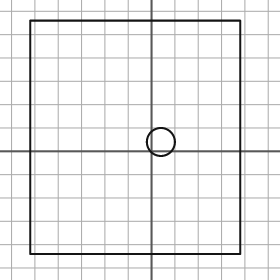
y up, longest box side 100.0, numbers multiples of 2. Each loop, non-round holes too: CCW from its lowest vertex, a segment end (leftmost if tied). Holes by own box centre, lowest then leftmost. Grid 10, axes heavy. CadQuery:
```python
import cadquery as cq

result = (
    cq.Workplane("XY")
    .moveTo(-52.0, -44.0)
    .lineTo(38.0, -44.0)
    .lineTo(38.0, 56.0)
    .lineTo(-52.0, 56.0)
    .close()
    .moveTo(4.0, 4.0)
    .circle(6.0)
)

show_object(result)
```